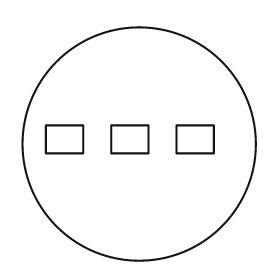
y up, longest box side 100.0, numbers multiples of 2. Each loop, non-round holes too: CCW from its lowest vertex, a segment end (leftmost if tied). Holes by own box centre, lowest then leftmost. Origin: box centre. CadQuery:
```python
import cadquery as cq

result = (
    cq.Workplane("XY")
    .moveTo(0.0, 0.0)
    .circle(50.0)
    .moveTo(-40.0, -4.0)
    .lineTo(-24.0, -4.0)
    .lineTo(-24.0, 8.0)
    .lineTo(-40.0, 8.0)
    .close()
    .moveTo(-12.0, -4.0)
    .lineTo(4.0, -4.0)
    .lineTo(4.0, 8.0)
    .lineTo(-12.0, 8.0)
    .close()
    .moveTo(16.0, -4.0)
    .lineTo(32.0, -4.0)
    .lineTo(32.0, 8.0)
    .lineTo(16.0, 8.0)
    .close()
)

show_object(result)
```